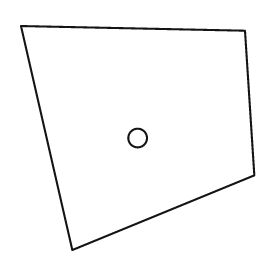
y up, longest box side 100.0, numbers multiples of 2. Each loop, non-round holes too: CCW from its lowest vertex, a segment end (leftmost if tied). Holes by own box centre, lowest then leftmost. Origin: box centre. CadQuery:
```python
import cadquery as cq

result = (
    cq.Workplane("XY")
    .moveTo(-28.0, -48.0)
    .lineTo(50.0, -16.0)
    .lineTo(46.0, 46.0)
    .lineTo(-50.0, 48.0)
    .close()
    .moveTo(0.0, 0.0)
    .circle(4.0)
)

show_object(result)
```